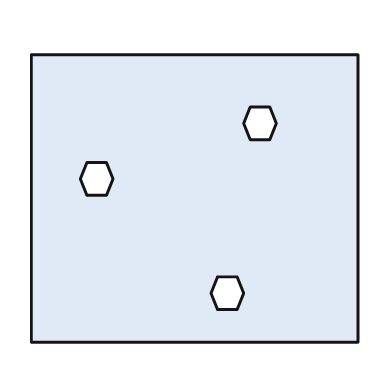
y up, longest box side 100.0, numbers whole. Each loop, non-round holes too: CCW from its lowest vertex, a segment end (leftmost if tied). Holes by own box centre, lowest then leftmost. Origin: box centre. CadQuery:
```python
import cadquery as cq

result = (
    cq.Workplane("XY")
    .moveTo(-50.0, -44.0)
    .lineTo(50.0, -44.0)
    .lineTo(50.0, 44.0)
    .lineTo(-50.0, 44.0)
    .close()
    .moveTo(7.0, -34.0)
    .lineTo(13.0, -34.0)
    .lineTo(15.0, -29.0)
    .lineTo(13.0, -24.0)
    .lineTo(7.0, -24.0)
    .lineTo(5.0, -29.0)
    .close()
    .moveTo(-33.0, 1.0)
    .lineTo(-27.0, 1.0)
    .lineTo(-25.0, 6.0)
    .lineTo(-27.0, 11.0)
    .lineTo(-33.0, 11.0)
    .lineTo(-35.0, 6.0)
    .close()
    .moveTo(17.0, 18.0)
    .lineTo(23.0, 18.0)
    .lineTo(25.0, 23.0)
    .lineTo(23.0, 28.0)
    .lineTo(17.0, 28.0)
    .lineTo(15.0, 23.0)
    .close()
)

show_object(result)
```